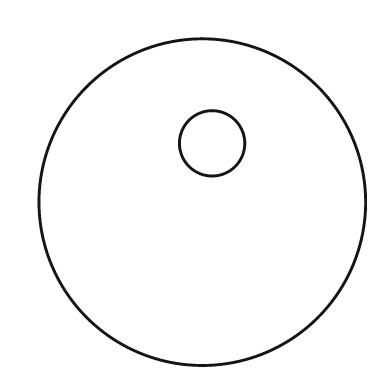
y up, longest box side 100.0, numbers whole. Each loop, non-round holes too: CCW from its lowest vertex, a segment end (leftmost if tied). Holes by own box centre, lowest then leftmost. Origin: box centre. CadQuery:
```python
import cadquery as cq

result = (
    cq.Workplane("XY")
    .moveTo(0.0, 0.0)
    .circle(50.0)
    .moveTo(3.0, 18.0)
    .circle(10.0)
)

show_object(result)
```